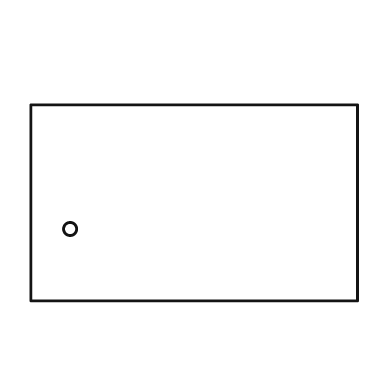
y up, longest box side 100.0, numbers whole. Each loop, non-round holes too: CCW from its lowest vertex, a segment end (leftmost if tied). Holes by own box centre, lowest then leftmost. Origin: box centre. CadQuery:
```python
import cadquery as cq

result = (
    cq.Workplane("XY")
    .moveTo(-50.0, -30.0)
    .lineTo(50.0, -30.0)
    .lineTo(50.0, 30.0)
    .lineTo(-50.0, 30.0)
    .close()
    .moveTo(-38.0, -8.0)
    .circle(2.0)
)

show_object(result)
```